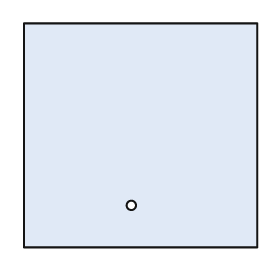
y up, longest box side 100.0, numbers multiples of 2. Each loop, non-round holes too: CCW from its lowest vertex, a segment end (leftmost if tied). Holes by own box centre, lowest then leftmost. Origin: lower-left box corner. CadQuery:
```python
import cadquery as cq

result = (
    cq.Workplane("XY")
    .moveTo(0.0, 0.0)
    .lineTo(100.0, 0.0)
    .lineTo(100.0, 96.0)
    .lineTo(0.0, 96.0)
    .close()
    .moveTo(46.0, 18.0)
    .circle(2.0)
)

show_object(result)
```